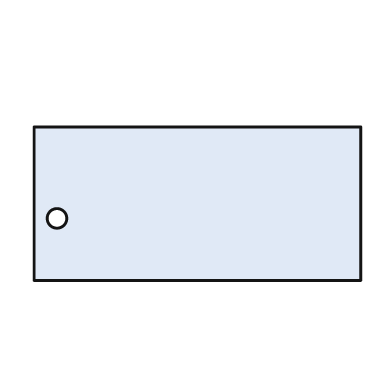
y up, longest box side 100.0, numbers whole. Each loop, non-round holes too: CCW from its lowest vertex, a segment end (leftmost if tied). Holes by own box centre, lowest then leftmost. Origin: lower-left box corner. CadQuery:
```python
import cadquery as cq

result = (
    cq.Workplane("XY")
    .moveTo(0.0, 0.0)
    .lineTo(100.0, 0.0)
    .lineTo(100.0, 47.0)
    .lineTo(0.0, 47.0)
    .close()
    .moveTo(7.0, 19.0)
    .circle(3.0)
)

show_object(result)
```